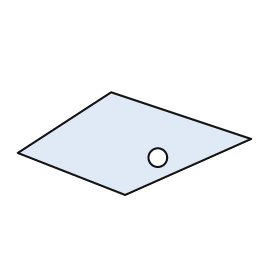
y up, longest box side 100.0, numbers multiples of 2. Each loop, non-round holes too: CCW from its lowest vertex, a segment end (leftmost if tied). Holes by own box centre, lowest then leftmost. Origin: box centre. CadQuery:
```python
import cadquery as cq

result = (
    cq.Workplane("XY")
    .moveTo(-4.0, -22.0)
    .lineTo(50.0, 2.0)
    .lineTo(-10.0, 22.0)
    .lineTo(-50.0, -4.0)
    .close()
    .moveTo(10.0, -6.0)
    .circle(4.0)
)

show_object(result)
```